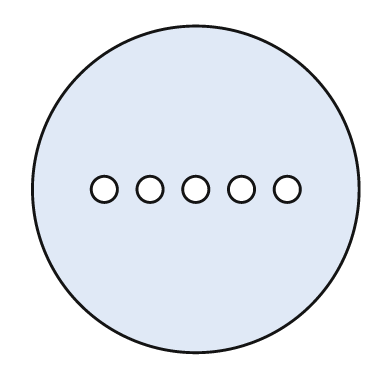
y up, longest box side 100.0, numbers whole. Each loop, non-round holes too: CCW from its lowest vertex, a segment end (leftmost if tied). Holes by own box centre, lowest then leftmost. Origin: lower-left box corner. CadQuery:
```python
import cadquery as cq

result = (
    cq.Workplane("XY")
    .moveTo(50.0, 50.0)
    .circle(50.0)
    .moveTo(22.0, 50.0)
    .circle(4.0)
    .moveTo(36.0, 50.0)
    .circle(4.0)
    .moveTo(50.0, 50.0)
    .circle(4.0)
    .moveTo(64.0, 50.0)
    .circle(4.0)
    .moveTo(78.0, 50.0)
    .circle(4.0)
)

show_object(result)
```